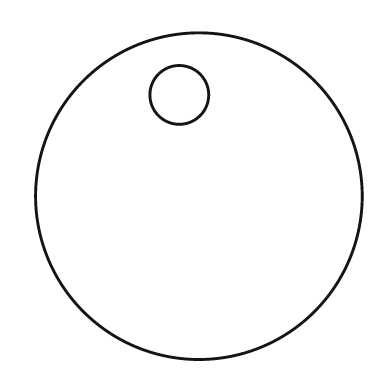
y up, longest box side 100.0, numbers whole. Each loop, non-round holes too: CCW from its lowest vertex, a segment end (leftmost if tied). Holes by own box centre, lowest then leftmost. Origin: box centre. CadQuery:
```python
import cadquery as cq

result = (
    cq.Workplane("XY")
    .moveTo(0.0, 0.0)
    .circle(50.0)
    .moveTo(-6.0, 31.0)
    .circle(9.0)
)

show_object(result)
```